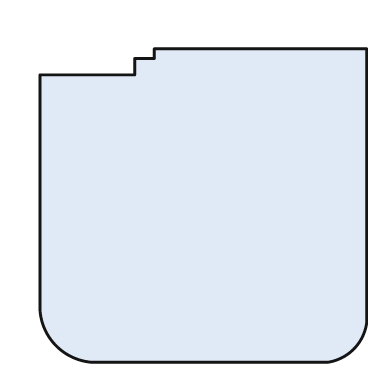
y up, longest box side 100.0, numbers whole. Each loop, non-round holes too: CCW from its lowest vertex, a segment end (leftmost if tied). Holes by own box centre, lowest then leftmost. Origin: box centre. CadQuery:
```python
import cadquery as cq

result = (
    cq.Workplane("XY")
    .moveTo(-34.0, -48.0)
    .lineTo(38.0, -48.0)
    .threePointArc((46.0, -44.0), (50.0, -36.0))
    .lineTo(50.0, 48.0)
    .lineTo(-15.0, 48.0)
    .lineTo(-15.0, 45.0)
    .lineTo(-21.0, 45.0)
    .lineTo(-21.0, 40.0)
    .lineTo(-50.0, 40.0)
    .lineTo(-50.0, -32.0)
    .threePointArc((-45.0, -43.0), (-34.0, -48.0))
    .close()
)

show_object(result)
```